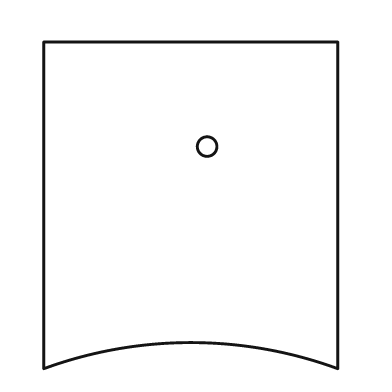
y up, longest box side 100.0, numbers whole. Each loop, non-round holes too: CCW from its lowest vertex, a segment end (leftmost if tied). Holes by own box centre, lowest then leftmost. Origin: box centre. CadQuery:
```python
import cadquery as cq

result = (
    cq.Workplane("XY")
    .moveTo(-45.0, -50.0)
    .threePointArc((0.0, -42.0), (45.0, -50.0))
    .lineTo(45.0, 50.0)
    .lineTo(-45.0, 50.0)
    .close()
    .moveTo(5.0, 18.0)
    .circle(3.0)
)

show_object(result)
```